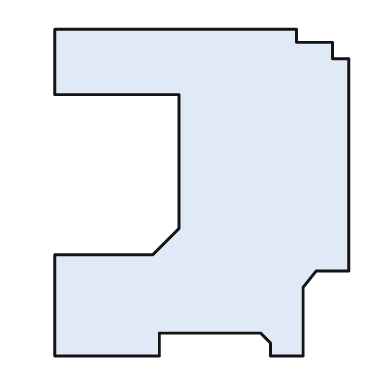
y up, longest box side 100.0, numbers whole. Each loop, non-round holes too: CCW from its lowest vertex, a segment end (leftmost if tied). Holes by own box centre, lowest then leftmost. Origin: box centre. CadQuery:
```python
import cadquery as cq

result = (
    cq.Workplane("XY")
    .moveTo(-45.0, -50.0)
    .lineTo(-13.0, -50.0)
    .lineTo(-13.0, -43.0)
    .lineTo(18.0, -43.0)
    .lineTo(21.0, -46.0)
    .lineTo(21.0, -50.0)
    .lineTo(31.0, -50.0)
    .lineTo(31.0, -29.0)
    .lineTo(35.0, -24.0)
    .lineTo(45.0, -24.0)
    .lineTo(45.0, 41.0)
    .lineTo(40.0, 41.0)
    .lineTo(40.0, 46.0)
    .lineTo(29.0, 46.0)
    .lineTo(29.0, 50.0)
    .lineTo(-45.0, 50.0)
    .lineTo(-45.0, 30.0)
    .lineTo(-7.0, 30.0)
    .lineTo(-7.0, -11.0)
    .lineTo(-15.0, -19.0)
    .lineTo(-45.0, -19.0)
    .close()
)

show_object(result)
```